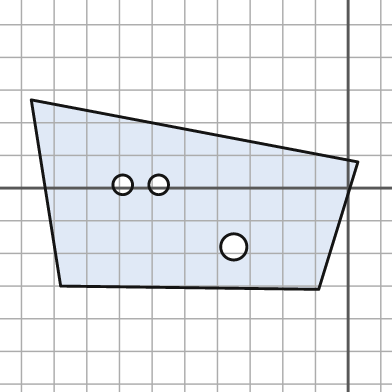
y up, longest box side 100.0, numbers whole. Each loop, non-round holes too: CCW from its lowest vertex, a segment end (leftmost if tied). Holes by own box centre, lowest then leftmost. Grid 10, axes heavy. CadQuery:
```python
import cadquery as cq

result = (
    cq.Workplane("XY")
    .moveTo(-9.0, -31.0)
    .lineTo(3.0, 8.0)
    .lineTo(-97.0, 27.0)
    .lineTo(-88.0, -30.0)
    .close()
    .moveTo(-35.0, -18.0)
    .circle(4.0)
    .moveTo(-69.0, 1.0)
    .circle(3.0)
    .moveTo(-58.0, 1.0)
    .circle(3.0)
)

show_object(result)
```